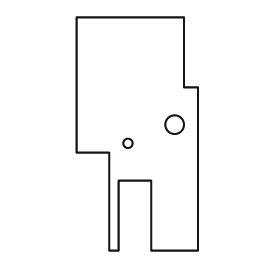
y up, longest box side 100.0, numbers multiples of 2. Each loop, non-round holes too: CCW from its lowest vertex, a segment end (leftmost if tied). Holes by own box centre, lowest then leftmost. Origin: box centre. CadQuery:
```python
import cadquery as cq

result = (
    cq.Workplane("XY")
    .moveTo(-12.0, -50.0)
    .lineTo(-8.0, -50.0)
    .lineTo(-8.0, -20.0)
    .lineTo(6.0, -20.0)
    .lineTo(6.0, -50.0)
    .lineTo(26.0, -50.0)
    .lineTo(26.0, 20.0)
    .lineTo(20.0, 20.0)
    .lineTo(20.0, 50.0)
    .lineTo(-26.0, 50.0)
    .lineTo(-26.0, -8.0)
    .lineTo(-12.0, -8.0)
    .close()
    .moveTo(-4.0, -4.0)
    .circle(2.0)
    .moveTo(16.0, 4.0)
    .circle(4.0)
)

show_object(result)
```